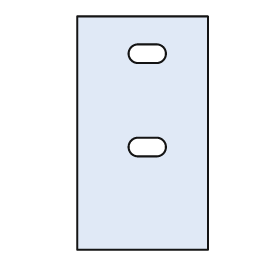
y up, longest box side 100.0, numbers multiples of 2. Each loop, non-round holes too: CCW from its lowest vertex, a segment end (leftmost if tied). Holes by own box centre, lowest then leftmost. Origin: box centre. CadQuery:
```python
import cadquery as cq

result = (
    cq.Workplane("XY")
    .moveTo(-28.0, -50.0)
    .lineTo(28.0, -50.0)
    .lineTo(28.0, 50.0)
    .lineTo(-28.0, 50.0)
    .close()
    .moveTo(-2.0, -10.0)
    .lineTo(6.0, -10.0)
    .threePointArc((10.0, -6.0), (6.0, -2.0))
    .lineTo(-2.0, -2.0)
    .threePointArc((-6.0, -6.0), (-2.0, -10.0))
    .close()
    .moveTo(-2.0, 30.0)
    .lineTo(6.0, 30.0)
    .threePointArc((10.0, 34.0), (6.0, 38.0))
    .lineTo(-2.0, 38.0)
    .threePointArc((-6.0, 34.0), (-2.0, 30.0))
    .close()
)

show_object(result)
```